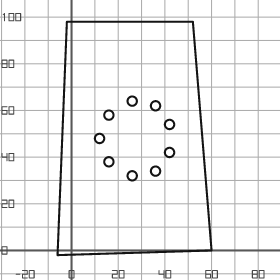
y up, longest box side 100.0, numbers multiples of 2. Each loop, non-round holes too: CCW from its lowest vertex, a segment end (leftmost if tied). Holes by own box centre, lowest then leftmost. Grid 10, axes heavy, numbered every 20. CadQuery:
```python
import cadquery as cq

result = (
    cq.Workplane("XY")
    .moveTo(-6.0, -2.0)
    .lineTo(60.0, 0.0)
    .lineTo(52.0, 98.0)
    .lineTo(-2.0, 98.0)
    .close()
    .moveTo(26.0, 32.0)
    .circle(2.0)
    .moveTo(36.0, 34.0)
    .circle(2.0)
    .moveTo(16.0, 38.0)
    .circle(2.0)
    .moveTo(42.0, 42.0)
    .circle(2.0)
    .moveTo(12.0, 48.0)
    .circle(2.0)
    .moveTo(42.0, 54.0)
    .circle(2.0)
    .moveTo(16.0, 58.0)
    .circle(2.0)
    .moveTo(36.0, 62.0)
    .circle(2.0)
    .moveTo(26.0, 64.0)
    .circle(2.0)
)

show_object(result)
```